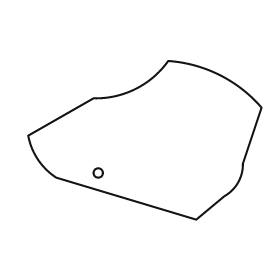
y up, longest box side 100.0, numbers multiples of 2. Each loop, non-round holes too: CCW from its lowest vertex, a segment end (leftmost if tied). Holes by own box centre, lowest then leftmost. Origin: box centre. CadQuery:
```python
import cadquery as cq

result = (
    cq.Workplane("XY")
    .moveTo(22.0, -34.0)
    .lineTo(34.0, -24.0)
    .threePointArc((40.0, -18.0), (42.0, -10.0))
    .lineTo(50.0, 14.0)
    .threePointArc((32.0, 28.0), (10.0, 34.0))
    .threePointArc((-4.0, 22.0), (-22.0, 18.0))
    .lineTo(-50.0, 2.0)
    .threePointArc((-46.0, -8.0), (-38.0, -16.0))
    .close()
    .moveTo(-20.0, -14.0)
    .circle(2.0)
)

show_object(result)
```